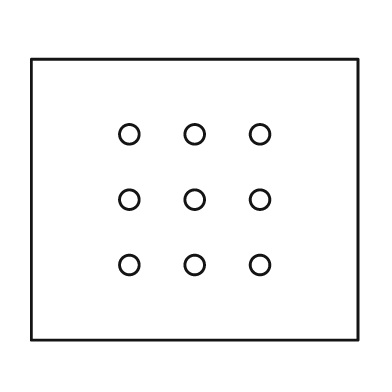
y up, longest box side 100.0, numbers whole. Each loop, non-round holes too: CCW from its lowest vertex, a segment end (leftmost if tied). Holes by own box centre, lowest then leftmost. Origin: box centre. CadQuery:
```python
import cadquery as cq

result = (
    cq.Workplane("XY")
    .moveTo(-50.0, -43.0)
    .lineTo(50.0, -43.0)
    .lineTo(50.0, 43.0)
    .lineTo(-50.0, 43.0)
    .close()
    .moveTo(-20.0, -20.0)
    .circle(3.0)
    .moveTo(0.0, -20.0)
    .circle(3.0)
    .moveTo(20.0, -20.0)
    .circle(3.0)
    .moveTo(-20.0, 0.0)
    .circle(3.0)
    .moveTo(0.0, 0.0)
    .circle(3.0)
    .moveTo(20.0, 0.0)
    .circle(3.0)
    .moveTo(-20.0, 20.0)
    .circle(3.0)
    .moveTo(0.0, 20.0)
    .circle(3.0)
    .moveTo(20.0, 20.0)
    .circle(3.0)
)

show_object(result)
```